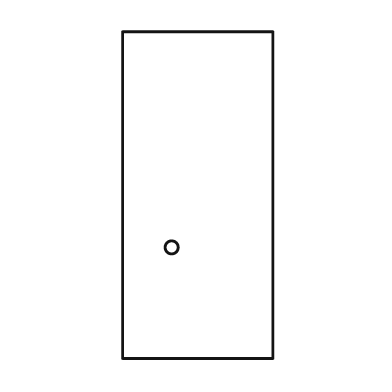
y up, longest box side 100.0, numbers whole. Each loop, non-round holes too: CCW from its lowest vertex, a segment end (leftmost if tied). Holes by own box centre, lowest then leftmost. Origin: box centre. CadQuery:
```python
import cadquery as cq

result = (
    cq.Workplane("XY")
    .moveTo(-23.0, -50.0)
    .lineTo(23.0, -50.0)
    .lineTo(23.0, 50.0)
    .lineTo(-23.0, 50.0)
    .close()
    .moveTo(-8.0, -16.0)
    .circle(2.0)
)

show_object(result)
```